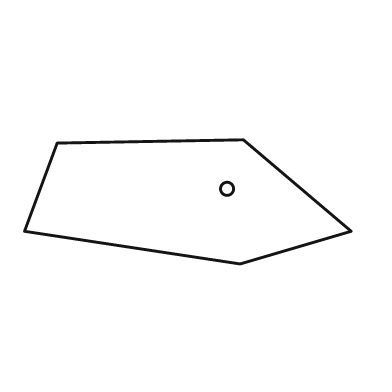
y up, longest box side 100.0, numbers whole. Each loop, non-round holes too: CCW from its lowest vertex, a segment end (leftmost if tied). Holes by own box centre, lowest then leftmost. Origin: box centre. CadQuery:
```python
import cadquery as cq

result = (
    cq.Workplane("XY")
    .moveTo(16.0, -19.0)
    .lineTo(50.0, -9.0)
    .lineTo(17.0, 19.0)
    .lineTo(-40.0, 18.0)
    .lineTo(-50.0, -9.0)
    .close()
    .moveTo(12.0, 4.0)
    .circle(2.0)
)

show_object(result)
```